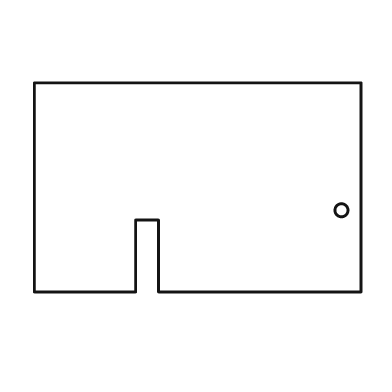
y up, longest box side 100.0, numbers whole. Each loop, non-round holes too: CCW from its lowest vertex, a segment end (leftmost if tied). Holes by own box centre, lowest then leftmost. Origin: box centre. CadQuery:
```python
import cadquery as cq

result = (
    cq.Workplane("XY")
    .moveTo(-50.0, -32.0)
    .lineTo(-19.0, -32.0)
    .lineTo(-19.0, -10.0)
    .lineTo(-12.0, -10.0)
    .lineTo(-12.0, -32.0)
    .lineTo(50.0, -32.0)
    .lineTo(50.0, 32.0)
    .lineTo(-50.0, 32.0)
    .close()
    .moveTo(44.0, -7.0)
    .circle(2.0)
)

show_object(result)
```